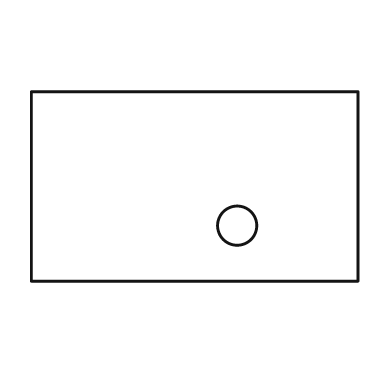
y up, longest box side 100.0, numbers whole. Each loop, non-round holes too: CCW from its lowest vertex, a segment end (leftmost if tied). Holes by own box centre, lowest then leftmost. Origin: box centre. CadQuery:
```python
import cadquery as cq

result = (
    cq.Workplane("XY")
    .moveTo(-50.0, -29.0)
    .lineTo(50.0, -29.0)
    .lineTo(50.0, 29.0)
    .lineTo(-50.0, 29.0)
    .close()
    .moveTo(13.0, -12.0)
    .circle(6.0)
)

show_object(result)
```